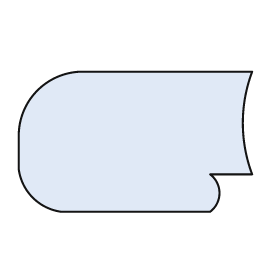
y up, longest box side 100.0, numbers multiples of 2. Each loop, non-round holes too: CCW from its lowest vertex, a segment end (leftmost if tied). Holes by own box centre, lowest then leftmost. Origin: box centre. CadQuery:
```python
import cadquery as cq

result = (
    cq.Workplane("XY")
    .moveTo(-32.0, -30.0)
    .lineTo(32.0, -30.0)
    .threePointArc((36.0, -22.0), (32.0, -14.0))
    .lineTo(50.0, -14.0)
    .threePointArc((46.0, 8.0), (50.0, 30.0))
    .lineTo(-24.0, 30.0)
    .threePointArc((-42.0, 22.0), (-50.0, 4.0))
    .lineTo(-50.0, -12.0)
    .threePointArc((-44.0, -24.0), (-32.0, -30.0))
    .close()
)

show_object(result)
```